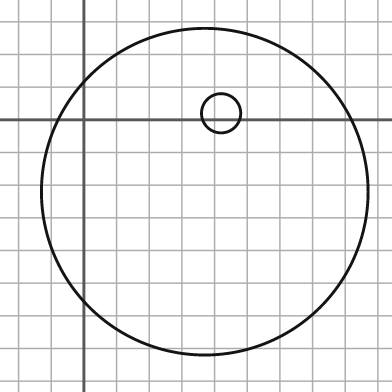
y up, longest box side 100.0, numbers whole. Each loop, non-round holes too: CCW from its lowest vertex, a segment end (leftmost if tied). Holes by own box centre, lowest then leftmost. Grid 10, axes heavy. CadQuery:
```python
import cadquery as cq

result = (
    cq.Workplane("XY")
    .moveTo(37.0, -22.0)
    .circle(50.0)
    .moveTo(42.0, 2.0)
    .circle(6.0)
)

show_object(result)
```